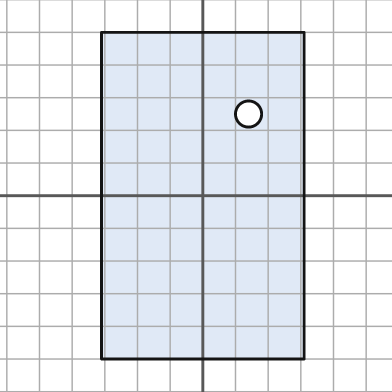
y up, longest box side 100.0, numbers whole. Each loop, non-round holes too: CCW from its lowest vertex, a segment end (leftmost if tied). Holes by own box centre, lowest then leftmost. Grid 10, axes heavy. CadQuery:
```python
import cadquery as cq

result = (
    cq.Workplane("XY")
    .moveTo(-31.0, -50.0)
    .lineTo(31.0, -50.0)
    .lineTo(31.0, 50.0)
    .lineTo(-31.0, 50.0)
    .close()
    .moveTo(14.0, 25.0)
    .circle(4.0)
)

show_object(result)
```